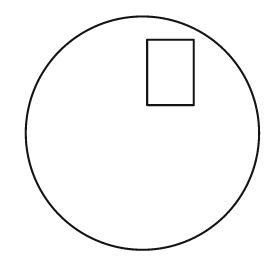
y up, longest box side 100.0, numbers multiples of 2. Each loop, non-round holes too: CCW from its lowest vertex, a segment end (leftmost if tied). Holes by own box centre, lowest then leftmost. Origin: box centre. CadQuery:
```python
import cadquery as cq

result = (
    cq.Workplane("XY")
    .moveTo(0.0, 0.0)
    .circle(50.0)
    .moveTo(2.0, 12.0)
    .lineTo(22.0, 12.0)
    .lineTo(22.0, 40.0)
    .lineTo(2.0, 40.0)
    .close()
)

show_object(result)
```